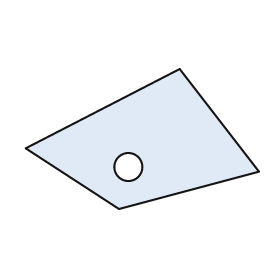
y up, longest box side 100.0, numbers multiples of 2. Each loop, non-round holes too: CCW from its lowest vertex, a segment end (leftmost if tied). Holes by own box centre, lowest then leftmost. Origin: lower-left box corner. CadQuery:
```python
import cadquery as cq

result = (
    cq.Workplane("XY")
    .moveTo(40.0, 0.0)
    .lineTo(100.0, 16.0)
    .lineTo(66.0, 60.0)
    .lineTo(0.0, 26.0)
    .close()
    .moveTo(44.0, 18.0)
    .circle(6.0)
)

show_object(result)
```